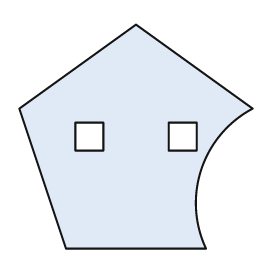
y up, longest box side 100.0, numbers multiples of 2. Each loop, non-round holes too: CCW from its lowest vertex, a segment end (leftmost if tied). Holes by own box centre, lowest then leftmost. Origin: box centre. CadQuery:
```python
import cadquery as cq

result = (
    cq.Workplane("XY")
    .moveTo(-30.0, -48.0)
    .lineTo(30.0, -48.0)
    .threePointArc((28.0, -14.0), (50.0, 12.0))
    .lineTo(0.0, 48.0)
    .lineTo(-50.0, 12.0)
    .close()
    .moveTo(-26.0, -6.0)
    .lineTo(-14.0, -6.0)
    .lineTo(-14.0, 6.0)
    .lineTo(-26.0, 6.0)
    .close()
    .moveTo(14.0, -6.0)
    .lineTo(26.0, -6.0)
    .lineTo(26.0, 6.0)
    .lineTo(14.0, 6.0)
    .close()
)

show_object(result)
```